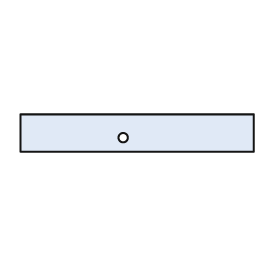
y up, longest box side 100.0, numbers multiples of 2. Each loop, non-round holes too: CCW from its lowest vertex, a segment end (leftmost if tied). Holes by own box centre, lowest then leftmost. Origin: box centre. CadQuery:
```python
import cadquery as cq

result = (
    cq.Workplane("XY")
    .moveTo(-50.0, -8.0)
    .lineTo(50.0, -8.0)
    .lineTo(50.0, 8.0)
    .lineTo(-50.0, 8.0)
    .close()
    .moveTo(-6.0, -2.0)
    .circle(2.0)
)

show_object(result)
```